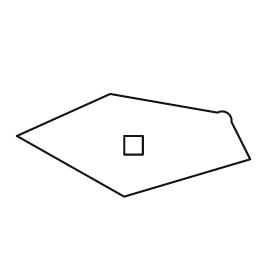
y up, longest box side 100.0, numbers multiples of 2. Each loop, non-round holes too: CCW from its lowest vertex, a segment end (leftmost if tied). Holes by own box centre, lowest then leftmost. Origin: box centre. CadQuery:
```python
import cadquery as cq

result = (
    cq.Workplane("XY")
    .moveTo(-4.0, -22.0)
    .lineTo(50.0, -6.0)
    .lineTo(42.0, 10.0)
    .threePointArc((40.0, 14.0), (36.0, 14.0))
    .lineTo(-10.0, 22.0)
    .lineTo(-50.0, 4.0)
    .close()
    .moveTo(-4.0, -4.0)
    .lineTo(4.0, -4.0)
    .lineTo(4.0, 4.0)
    .lineTo(-4.0, 4.0)
    .close()
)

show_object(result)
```